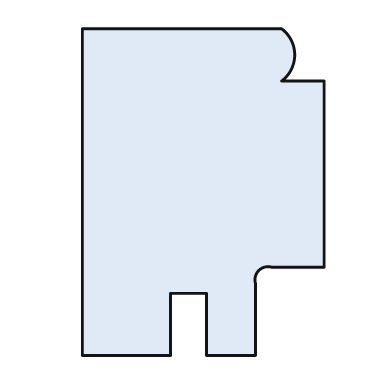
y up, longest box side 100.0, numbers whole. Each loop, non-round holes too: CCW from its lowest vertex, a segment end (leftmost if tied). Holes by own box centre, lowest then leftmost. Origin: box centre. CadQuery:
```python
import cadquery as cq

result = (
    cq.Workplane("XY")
    .moveTo(-37.0, -50.0)
    .lineTo(-10.0, -50.0)
    .lineTo(-10.0, -31.0)
    .lineTo(1.0, -31.0)
    .lineTo(1.0, -50.0)
    .lineTo(16.0, -50.0)
    .lineTo(16.0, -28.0)
    .threePointArc((17.0, -24.0), (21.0, -23.0))
    .lineTo(37.0, -23.0)
    .lineTo(37.0, 34.0)
    .lineTo(24.0, 34.0)
    .threePointArc((28.0, 42.0), (24.0, 50.0))
    .lineTo(-37.0, 50.0)
    .close()
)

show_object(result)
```